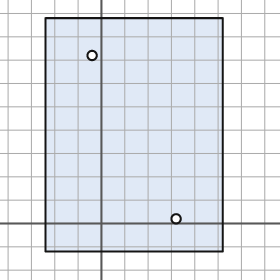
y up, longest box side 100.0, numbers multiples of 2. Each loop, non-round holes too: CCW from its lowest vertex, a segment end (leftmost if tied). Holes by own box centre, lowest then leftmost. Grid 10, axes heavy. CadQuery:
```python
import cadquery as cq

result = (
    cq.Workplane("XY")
    .moveTo(-24.0, -12.0)
    .lineTo(52.0, -12.0)
    .lineTo(52.0, 88.0)
    .lineTo(-24.0, 88.0)
    .close()
    .moveTo(32.0, 2.0)
    .circle(2.0)
    .moveTo(-4.0, 72.0)
    .circle(2.0)
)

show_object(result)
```